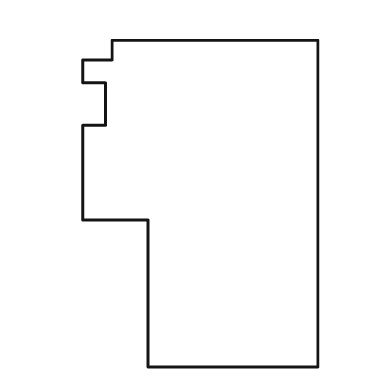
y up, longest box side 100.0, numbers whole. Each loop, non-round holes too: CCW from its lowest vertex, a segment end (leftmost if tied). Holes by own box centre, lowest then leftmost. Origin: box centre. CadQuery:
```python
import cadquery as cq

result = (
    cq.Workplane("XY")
    .moveTo(-16.0, -50.0)
    .lineTo(36.0, -50.0)
    .lineTo(36.0, 50.0)
    .lineTo(-27.0, 50.0)
    .lineTo(-27.0, 44.0)
    .lineTo(-36.0, 44.0)
    .lineTo(-36.0, 37.0)
    .lineTo(-29.0, 37.0)
    .lineTo(-29.0, 24.0)
    .lineTo(-36.0, 24.0)
    .lineTo(-36.0, -5.0)
    .lineTo(-16.0, -5.0)
    .close()
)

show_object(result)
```